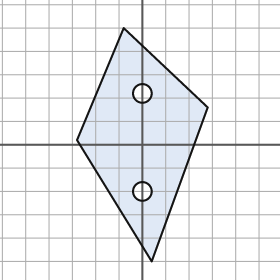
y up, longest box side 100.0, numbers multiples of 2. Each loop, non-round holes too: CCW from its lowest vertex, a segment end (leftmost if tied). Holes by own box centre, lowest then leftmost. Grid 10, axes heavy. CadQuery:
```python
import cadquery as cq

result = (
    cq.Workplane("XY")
    .moveTo(4.0, -50.0)
    .lineTo(28.0, 16.0)
    .lineTo(-8.0, 50.0)
    .lineTo(-28.0, 2.0)
    .close()
    .moveTo(0.0, -20.0)
    .circle(4.0)
    .moveTo(0.0, 22.0)
    .circle(4.0)
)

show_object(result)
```